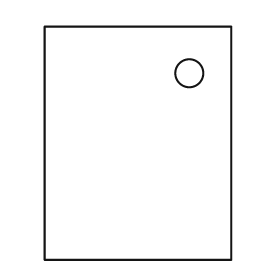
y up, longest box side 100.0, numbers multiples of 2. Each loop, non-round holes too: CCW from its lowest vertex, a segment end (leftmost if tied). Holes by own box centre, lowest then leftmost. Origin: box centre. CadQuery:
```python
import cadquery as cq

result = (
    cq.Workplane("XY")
    .moveTo(-40.0, -50.0)
    .lineTo(40.0, -50.0)
    .lineTo(40.0, 50.0)
    .lineTo(-40.0, 50.0)
    .close()
    .moveTo(22.0, 30.0)
    .circle(6.0)
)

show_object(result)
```